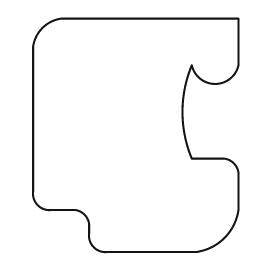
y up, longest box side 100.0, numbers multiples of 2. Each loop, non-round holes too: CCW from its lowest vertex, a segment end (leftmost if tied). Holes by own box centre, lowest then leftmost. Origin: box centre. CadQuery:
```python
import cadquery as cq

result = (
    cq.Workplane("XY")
    .moveTo(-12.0, -50.0)
    .lineTo(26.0, -50.0)
    .threePointArc((38.0, -44.0), (44.0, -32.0))
    .lineTo(44.0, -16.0)
    .threePointArc((42.0, -12.0), (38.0, -10.0))
    .lineTo(24.0, -10.0)
    .threePointArc((20.0, 10.0), (24.0, 30.0))
    .threePointArc((34.0, 22.0), (44.0, 30.0))
    .lineTo(44.0, 50.0)
    .lineTo(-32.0, 50.0)
    .threePointArc((-40.0, 46.0), (-44.0, 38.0))
    .lineTo(-44.0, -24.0)
    .threePointArc((-42.0, -30.0), (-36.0, -32.0))
    .lineTo(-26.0, -32.0)
    .threePointArc((-22.0, -34.0), (-20.0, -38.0))
    .lineTo(-20.0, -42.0)
    .threePointArc((-18.0, -48.0), (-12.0, -50.0))
    .close()
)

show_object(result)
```